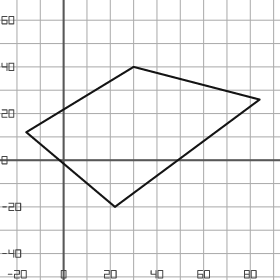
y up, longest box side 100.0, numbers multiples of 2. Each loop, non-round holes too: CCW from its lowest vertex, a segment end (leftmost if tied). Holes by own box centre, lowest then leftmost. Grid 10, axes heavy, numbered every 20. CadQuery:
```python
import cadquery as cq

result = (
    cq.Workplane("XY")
    .moveTo(22.0, -20.0)
    .lineTo(84.0, 26.0)
    .lineTo(30.0, 40.0)
    .lineTo(-16.0, 12.0)
    .close()
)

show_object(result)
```